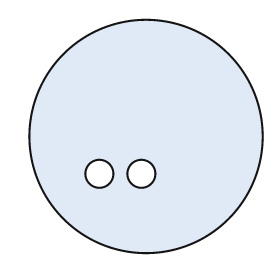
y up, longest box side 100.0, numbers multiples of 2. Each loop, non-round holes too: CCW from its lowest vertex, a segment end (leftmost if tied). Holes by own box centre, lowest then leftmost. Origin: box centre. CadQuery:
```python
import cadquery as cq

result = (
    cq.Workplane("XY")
    .moveTo(0.0, 0.0)
    .circle(50.0)
    .moveTo(-20.0, -16.0)
    .circle(6.0)
    .moveTo(-2.0, -16.0)
    .circle(6.0)
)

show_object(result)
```